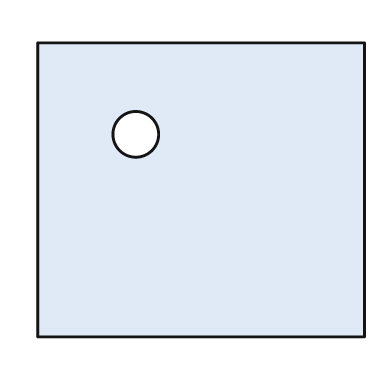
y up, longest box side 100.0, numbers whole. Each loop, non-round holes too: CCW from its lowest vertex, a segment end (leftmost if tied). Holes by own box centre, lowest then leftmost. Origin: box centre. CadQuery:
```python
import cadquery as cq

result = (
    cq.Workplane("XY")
    .moveTo(-50.0, -45.0)
    .lineTo(50.0, -45.0)
    .lineTo(50.0, 45.0)
    .lineTo(-50.0, 45.0)
    .close()
    .moveTo(-20.0, 17.0)
    .circle(7.0)
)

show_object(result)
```